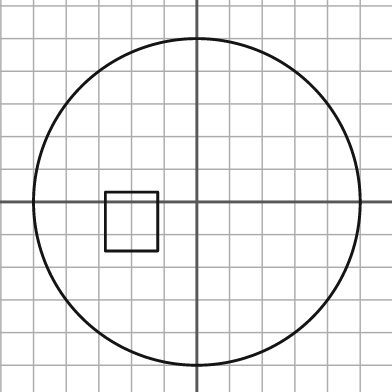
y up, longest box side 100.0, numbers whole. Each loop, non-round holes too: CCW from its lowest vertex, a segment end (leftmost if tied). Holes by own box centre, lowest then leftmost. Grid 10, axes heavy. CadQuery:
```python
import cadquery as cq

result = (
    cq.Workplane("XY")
    .moveTo(0.0, 0.0)
    .circle(50.0)
    .moveTo(-28.0, -15.0)
    .lineTo(-12.0, -15.0)
    .lineTo(-12.0, 3.0)
    .lineTo(-28.0, 3.0)
    .close()
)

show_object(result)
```